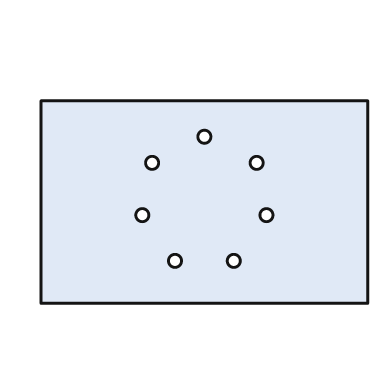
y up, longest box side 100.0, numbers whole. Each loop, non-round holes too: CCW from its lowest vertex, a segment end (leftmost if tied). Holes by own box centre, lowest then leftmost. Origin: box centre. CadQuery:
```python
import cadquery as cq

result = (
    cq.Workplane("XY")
    .moveTo(-50.0, -31.0)
    .lineTo(50.0, -31.0)
    .lineTo(50.0, 31.0)
    .lineTo(-50.0, 31.0)
    .close()
    .moveTo(-9.0, -18.0)
    .circle(2.0)
    .moveTo(9.0, -18.0)
    .circle(2.0)
    .moveTo(-19.0, -4.0)
    .circle(2.0)
    .moveTo(19.0, -4.0)
    .circle(2.0)
    .moveTo(-16.0, 12.0)
    .circle(2.0)
    .moveTo(16.0, 12.0)
    .circle(2.0)
    .moveTo(0.0, 20.0)
    .circle(2.0)
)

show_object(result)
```